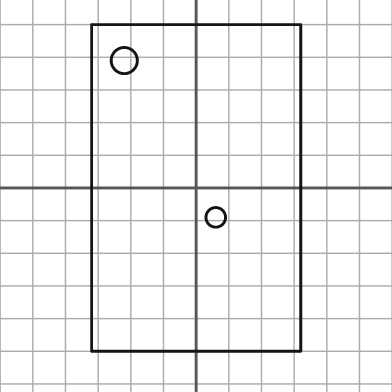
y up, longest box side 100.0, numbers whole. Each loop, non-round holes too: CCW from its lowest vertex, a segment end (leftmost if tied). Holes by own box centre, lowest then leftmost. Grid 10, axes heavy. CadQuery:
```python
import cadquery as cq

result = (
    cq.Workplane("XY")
    .moveTo(-32.0, -50.0)
    .lineTo(32.0, -50.0)
    .lineTo(32.0, 50.0)
    .lineTo(-32.0, 50.0)
    .close()
    .moveTo(6.0, -9.0)
    .circle(3.0)
    .moveTo(-22.0, 39.0)
    .circle(4.0)
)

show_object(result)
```